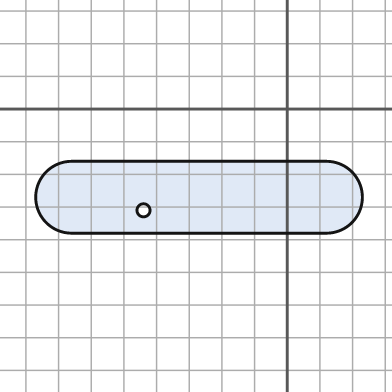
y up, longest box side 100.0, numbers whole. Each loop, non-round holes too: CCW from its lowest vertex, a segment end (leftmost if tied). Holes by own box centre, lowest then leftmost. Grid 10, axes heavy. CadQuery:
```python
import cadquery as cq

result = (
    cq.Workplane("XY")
    .moveTo(-66.0, -38.0)
    .lineTo(12.0, -38.0)
    .threePointArc((23.0, -27.0), (12.0, -16.0))
    .lineTo(-66.0, -16.0)
    .threePointArc((-77.0, -27.0), (-66.0, -38.0))
    .close()
    .moveTo(-44.0, -31.0)
    .circle(2.0)
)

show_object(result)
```